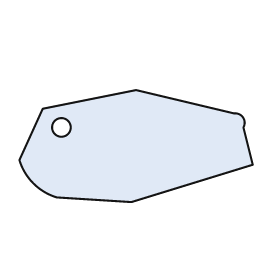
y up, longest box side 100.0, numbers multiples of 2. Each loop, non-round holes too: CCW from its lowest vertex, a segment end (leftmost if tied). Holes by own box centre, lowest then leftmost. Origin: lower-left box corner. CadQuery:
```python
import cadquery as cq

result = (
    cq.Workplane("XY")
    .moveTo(48.0, 0.0)
    .lineTo(100.0, 16.0)
    .lineTo(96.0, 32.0)
    .threePointArc((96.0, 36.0), (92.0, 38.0))
    .lineTo(50.0, 48.0)
    .lineTo(10.0, 40.0)
    .lineTo(0.0, 18.0)
    .threePointArc((6.0, 8.0), (16.0, 2.0))
    .close()
    .moveTo(18.0, 32.0)
    .circle(4.0)
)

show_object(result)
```